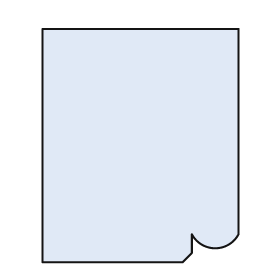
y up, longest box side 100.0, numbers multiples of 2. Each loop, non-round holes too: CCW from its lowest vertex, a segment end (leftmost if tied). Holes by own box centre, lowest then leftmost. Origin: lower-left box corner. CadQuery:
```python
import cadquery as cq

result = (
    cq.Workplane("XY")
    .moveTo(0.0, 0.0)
    .lineTo(60.0, 0.0)
    .lineTo(64.0, 4.0)
    .lineTo(64.0, 12.0)
    .threePointArc((74.0, 6.0), (84.0, 12.0))
    .lineTo(84.0, 100.0)
    .lineTo(0.0, 100.0)
    .close()
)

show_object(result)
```